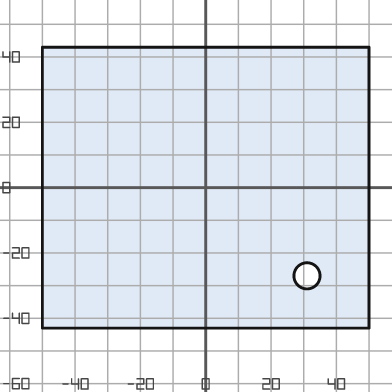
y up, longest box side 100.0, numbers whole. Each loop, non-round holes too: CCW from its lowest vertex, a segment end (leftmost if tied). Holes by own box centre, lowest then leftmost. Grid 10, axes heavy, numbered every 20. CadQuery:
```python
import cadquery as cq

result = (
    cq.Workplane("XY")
    .moveTo(-50.0, -43.0)
    .lineTo(50.0, -43.0)
    .lineTo(50.0, 43.0)
    .lineTo(-50.0, 43.0)
    .close()
    .moveTo(31.0, -27.0)
    .circle(4.0)
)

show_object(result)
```